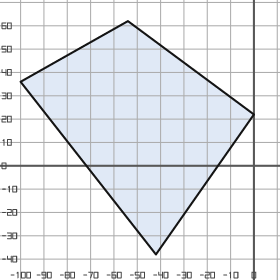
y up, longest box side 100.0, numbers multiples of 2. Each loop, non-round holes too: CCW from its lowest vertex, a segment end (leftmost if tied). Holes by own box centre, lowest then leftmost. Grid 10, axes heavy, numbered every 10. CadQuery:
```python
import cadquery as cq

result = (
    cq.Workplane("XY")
    .moveTo(-42.0, -38.0)
    .lineTo(0.0, 22.0)
    .lineTo(-54.0, 62.0)
    .lineTo(-100.0, 36.0)
    .close()
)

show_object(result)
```